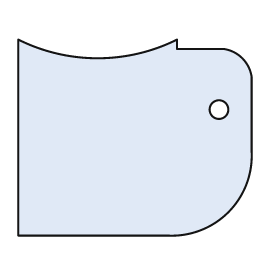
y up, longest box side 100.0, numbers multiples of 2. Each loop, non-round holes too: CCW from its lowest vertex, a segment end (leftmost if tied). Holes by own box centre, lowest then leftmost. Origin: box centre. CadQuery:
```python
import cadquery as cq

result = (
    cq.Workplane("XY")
    .moveTo(-50.0, -42.0)
    .lineTo(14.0, -42.0)
    .threePointArc((40.0, -32.0), (50.0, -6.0))
    .lineTo(50.0, 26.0)
    .threePointArc((46.0, 34.0), (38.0, 38.0))
    .lineTo(18.0, 38.0)
    .lineTo(18.0, 42.0)
    .threePointArc((-16.0, 34.0), (-50.0, 42.0))
    .close()
    .moveTo(36.0, 12.0)
    .circle(4.0)
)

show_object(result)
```